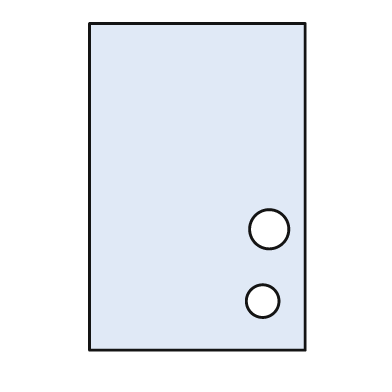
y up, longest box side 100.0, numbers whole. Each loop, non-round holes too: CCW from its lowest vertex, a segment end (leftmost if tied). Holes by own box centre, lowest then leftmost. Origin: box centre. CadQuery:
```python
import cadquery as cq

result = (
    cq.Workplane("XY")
    .moveTo(-33.0, -50.0)
    .lineTo(33.0, -50.0)
    .lineTo(33.0, 50.0)
    .lineTo(-33.0, 50.0)
    .close()
    .moveTo(20.0, -35.0)
    .circle(5.0)
    .moveTo(22.0, -13.0)
    .circle(6.0)
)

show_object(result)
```